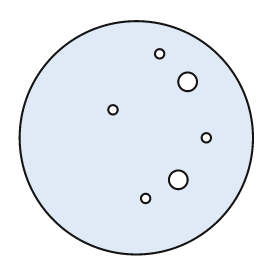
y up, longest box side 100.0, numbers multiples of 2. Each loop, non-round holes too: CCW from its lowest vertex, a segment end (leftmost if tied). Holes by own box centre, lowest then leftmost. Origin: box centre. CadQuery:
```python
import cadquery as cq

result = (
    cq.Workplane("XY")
    .moveTo(0.0, 0.0)
    .circle(50.0)
    .moveTo(4.0, -26.0)
    .circle(2.0)
    .moveTo(18.0, -18.0)
    .circle(4.0)
    .moveTo(30.0, 0.0)
    .circle(2.0)
    .moveTo(-10.0, 12.0)
    .circle(2.0)
    .moveTo(22.0, 24.0)
    .circle(4.0)
    .moveTo(10.0, 36.0)
    .circle(2.0)
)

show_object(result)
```